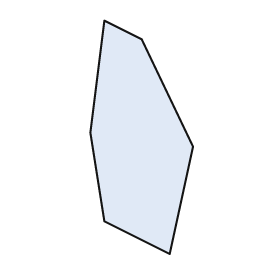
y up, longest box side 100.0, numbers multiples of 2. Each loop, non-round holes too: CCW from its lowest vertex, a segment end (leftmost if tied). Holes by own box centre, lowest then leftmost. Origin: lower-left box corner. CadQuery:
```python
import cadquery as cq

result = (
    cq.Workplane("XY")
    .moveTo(34.0, 0.0)
    .lineTo(44.0, 46.0)
    .lineTo(22.0, 92.0)
    .lineTo(6.0, 100.0)
    .lineTo(0.0, 52.0)
    .lineTo(6.0, 14.0)
    .close()
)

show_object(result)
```